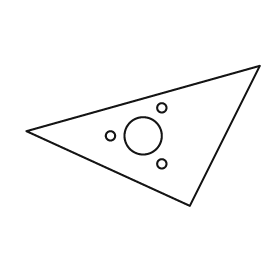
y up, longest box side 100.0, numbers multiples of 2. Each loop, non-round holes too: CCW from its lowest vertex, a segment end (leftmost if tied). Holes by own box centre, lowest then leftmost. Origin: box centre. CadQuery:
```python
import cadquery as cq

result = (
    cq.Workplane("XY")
    .moveTo(20.0, -30.0)
    .lineTo(50.0, 30.0)
    .lineTo(-50.0, 2.0)
    .close()
    .moveTo(8.0, -12.0)
    .circle(2.0)
    .moveTo(-14.0, 0.0)
    .circle(2.0)
    .moveTo(0.0, 0.0)
    .circle(8.0)
    .moveTo(8.0, 12.0)
    .circle(2.0)
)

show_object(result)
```